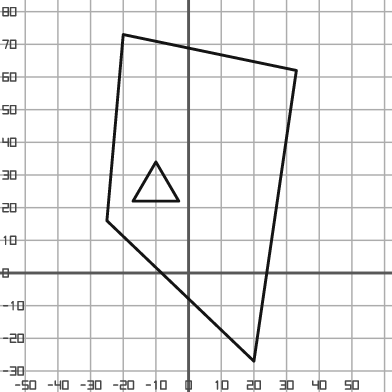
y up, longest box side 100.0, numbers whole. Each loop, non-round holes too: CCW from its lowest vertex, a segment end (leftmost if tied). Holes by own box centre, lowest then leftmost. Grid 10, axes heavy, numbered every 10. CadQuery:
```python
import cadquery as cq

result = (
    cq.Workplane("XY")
    .moveTo(20.0, -27.0)
    .lineTo(33.0, 62.0)
    .lineTo(-20.0, 73.0)
    .lineTo(-25.0, 16.0)
    .close()
    .moveTo(-17.0, 22.0)
    .lineTo(-3.0, 22.0)
    .lineTo(-10.0, 34.0)
    .close()
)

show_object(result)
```